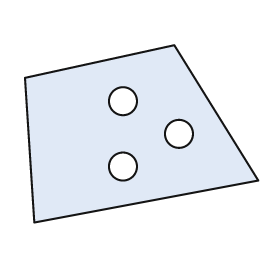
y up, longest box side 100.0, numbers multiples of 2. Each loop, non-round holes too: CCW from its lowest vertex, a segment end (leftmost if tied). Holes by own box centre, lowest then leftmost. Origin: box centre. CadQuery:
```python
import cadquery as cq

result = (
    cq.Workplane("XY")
    .moveTo(-46.0, -38.0)
    .lineTo(50.0, -20.0)
    .lineTo(14.0, 38.0)
    .lineTo(-50.0, 24.0)
    .close()
    .moveTo(-8.0, -14.0)
    .circle(6.0)
    .moveTo(16.0, 0.0)
    .circle(6.0)
    .moveTo(-8.0, 14.0)
    .circle(6.0)
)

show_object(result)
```